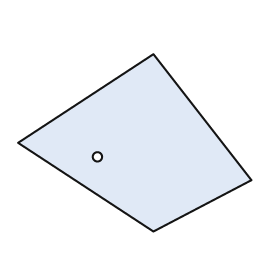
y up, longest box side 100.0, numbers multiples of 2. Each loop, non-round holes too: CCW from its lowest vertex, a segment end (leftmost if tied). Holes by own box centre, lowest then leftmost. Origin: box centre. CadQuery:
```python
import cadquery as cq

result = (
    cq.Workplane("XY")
    .moveTo(8.0, -38.0)
    .lineTo(50.0, -16.0)
    .lineTo(8.0, 38.0)
    .lineTo(-50.0, 0.0)
    .close()
    .moveTo(-16.0, -6.0)
    .circle(2.0)
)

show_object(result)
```